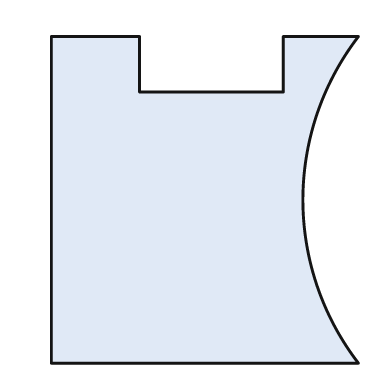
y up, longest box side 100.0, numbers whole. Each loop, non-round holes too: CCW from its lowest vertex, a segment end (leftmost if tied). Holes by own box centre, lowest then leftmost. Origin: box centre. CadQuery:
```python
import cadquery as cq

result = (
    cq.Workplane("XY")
    .moveTo(-47.0, -50.0)
    .lineTo(47.0, -50.0)
    .threePointArc((30.0, 0.0), (47.0, 50.0))
    .lineTo(24.0, 50.0)
    .lineTo(24.0, 33.0)
    .lineTo(-20.0, 33.0)
    .lineTo(-20.0, 50.0)
    .lineTo(-47.0, 50.0)
    .close()
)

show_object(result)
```